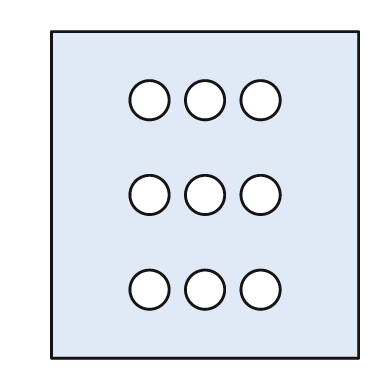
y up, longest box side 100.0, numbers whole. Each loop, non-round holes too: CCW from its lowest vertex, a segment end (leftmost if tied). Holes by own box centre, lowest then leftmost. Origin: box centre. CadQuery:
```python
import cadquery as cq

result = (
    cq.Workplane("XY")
    .moveTo(-47.0, -50.0)
    .lineTo(47.0, -50.0)
    .lineTo(47.0, 50.0)
    .lineTo(-47.0, 50.0)
    .close()
    .moveTo(-17.0, -29.0)
    .circle(6.0)
    .moveTo(0.0, -29.0)
    .circle(6.0)
    .moveTo(17.0, -29.0)
    .circle(6.0)
    .moveTo(-17.0, 0.0)
    .circle(6.0)
    .moveTo(0.0, 0.0)
    .circle(6.0)
    .moveTo(17.0, 0.0)
    .circle(6.0)
    .moveTo(-17.0, 29.0)
    .circle(6.0)
    .moveTo(0.0, 29.0)
    .circle(6.0)
    .moveTo(17.0, 29.0)
    .circle(6.0)
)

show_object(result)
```